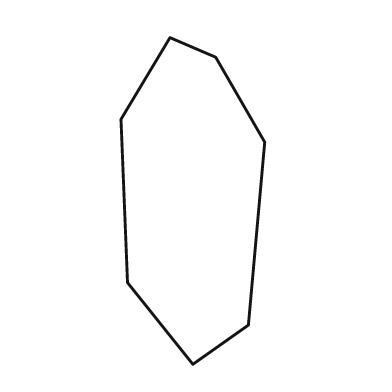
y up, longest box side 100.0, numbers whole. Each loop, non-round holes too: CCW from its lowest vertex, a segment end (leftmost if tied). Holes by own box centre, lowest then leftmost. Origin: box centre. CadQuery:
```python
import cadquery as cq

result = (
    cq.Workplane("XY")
    .moveTo(0.0, -50.0)
    .lineTo(17.0, -38.0)
    .lineTo(22.0, 18.0)
    .lineTo(7.0, 44.0)
    .lineTo(-7.0, 50.0)
    .lineTo(-22.0, 25.0)
    .lineTo(-20.0, -25.0)
    .close()
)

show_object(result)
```